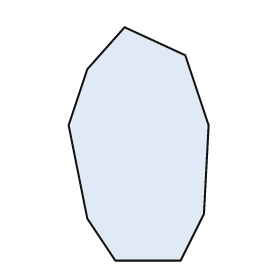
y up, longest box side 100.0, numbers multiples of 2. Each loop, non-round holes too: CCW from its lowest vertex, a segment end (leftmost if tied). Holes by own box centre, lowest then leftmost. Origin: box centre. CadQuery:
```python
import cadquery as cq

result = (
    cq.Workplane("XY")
    .moveTo(-10.0, -50.0)
    .lineTo(18.0, -50.0)
    .lineTo(28.0, -30.0)
    .lineTo(30.0, 8.0)
    .lineTo(20.0, 38.0)
    .lineTo(-6.0, 50.0)
    .lineTo(-22.0, 32.0)
    .lineTo(-30.0, 8.0)
    .lineTo(-22.0, -32.0)
    .close()
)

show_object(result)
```